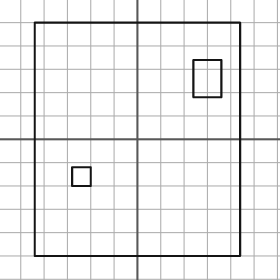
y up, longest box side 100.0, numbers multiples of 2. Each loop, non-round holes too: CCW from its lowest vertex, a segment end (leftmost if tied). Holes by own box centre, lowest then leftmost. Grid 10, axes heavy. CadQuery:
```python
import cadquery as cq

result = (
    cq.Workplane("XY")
    .moveTo(-44.0, -50.0)
    .lineTo(44.0, -50.0)
    .lineTo(44.0, 50.0)
    .lineTo(-44.0, 50.0)
    .close()
    .moveTo(-28.0, -20.0)
    .lineTo(-20.0, -20.0)
    .lineTo(-20.0, -12.0)
    .lineTo(-28.0, -12.0)
    .close()
    .moveTo(24.0, 18.0)
    .lineTo(36.0, 18.0)
    .lineTo(36.0, 34.0)
    .lineTo(24.0, 34.0)
    .close()
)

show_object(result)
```